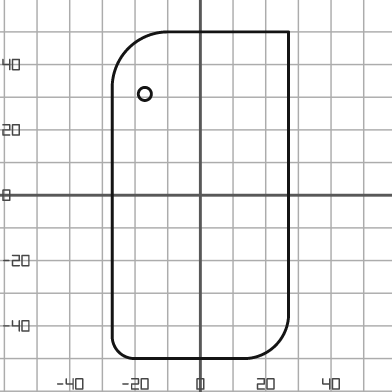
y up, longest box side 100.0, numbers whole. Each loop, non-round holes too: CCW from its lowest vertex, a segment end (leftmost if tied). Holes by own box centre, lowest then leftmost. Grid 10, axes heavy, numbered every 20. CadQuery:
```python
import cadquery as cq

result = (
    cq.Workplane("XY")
    .moveTo(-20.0, -50.0)
    .lineTo(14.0, -50.0)
    .threePointArc((23.0, -46.0), (27.0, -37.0))
    .lineTo(27.0, 50.0)
    .lineTo(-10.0, 50.0)
    .threePointArc((-22.0, 45.0), (-27.0, 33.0))
    .lineTo(-27.0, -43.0)
    .threePointArc((-25.0, -48.0), (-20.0, -50.0))
    .close()
    .moveTo(-17.0, 31.0)
    .circle(2.0)
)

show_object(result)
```